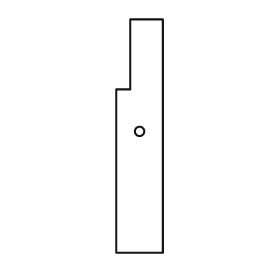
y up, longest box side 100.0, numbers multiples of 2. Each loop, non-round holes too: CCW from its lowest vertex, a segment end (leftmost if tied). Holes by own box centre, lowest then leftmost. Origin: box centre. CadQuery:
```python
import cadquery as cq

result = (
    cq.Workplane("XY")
    .moveTo(-10.0, -50.0)
    .lineTo(10.0, -50.0)
    .lineTo(10.0, 50.0)
    .lineTo(-4.0, 50.0)
    .lineTo(-4.0, 20.0)
    .lineTo(-10.0, 20.0)
    .close()
    .moveTo(0.0, 2.0)
    .circle(2.0)
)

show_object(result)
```